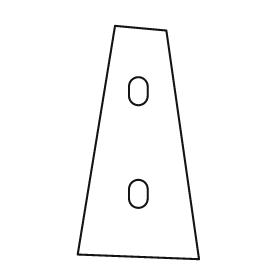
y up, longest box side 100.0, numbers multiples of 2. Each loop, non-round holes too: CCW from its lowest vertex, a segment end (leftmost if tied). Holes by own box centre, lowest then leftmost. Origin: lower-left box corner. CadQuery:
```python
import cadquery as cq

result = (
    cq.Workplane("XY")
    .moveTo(52.0, 0.0)
    .lineTo(38.0, 98.0)
    .lineTo(16.0, 100.0)
    .lineTo(0.0, 2.0)
    .close()
    .moveTo(22.0, 26.0)
    .threePointArc((26.0, 22.0), (30.0, 26.0))
    .lineTo(30.0, 30.0)
    .threePointArc((26.0, 34.0), (22.0, 30.0))
    .close()
    .moveTo(22.0, 70.0)
    .threePointArc((26.0, 66.0), (30.0, 70.0))
    .lineTo(30.0, 74.0)
    .threePointArc((26.0, 78.0), (22.0, 74.0))
    .close()
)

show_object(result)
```